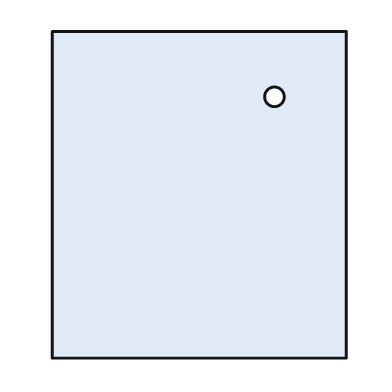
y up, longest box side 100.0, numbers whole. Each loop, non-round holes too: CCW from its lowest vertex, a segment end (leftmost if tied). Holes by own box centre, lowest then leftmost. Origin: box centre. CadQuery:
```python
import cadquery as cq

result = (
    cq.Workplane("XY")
    .moveTo(-45.0, -50.0)
    .lineTo(45.0, -50.0)
    .lineTo(45.0, 50.0)
    .lineTo(-45.0, 50.0)
    .close()
    .moveTo(23.0, 30.0)
    .circle(3.0)
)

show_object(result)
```